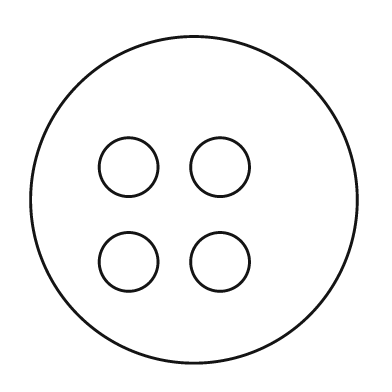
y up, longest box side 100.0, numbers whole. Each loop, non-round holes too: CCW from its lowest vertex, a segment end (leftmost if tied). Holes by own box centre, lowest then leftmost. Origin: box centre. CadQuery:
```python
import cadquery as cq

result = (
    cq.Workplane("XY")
    .moveTo(0.0, 0.0)
    .circle(50.0)
    .moveTo(-20.0, -19.0)
    .circle(9.0)
    .moveTo(8.0, -19.0)
    .circle(9.0)
    .moveTo(-20.0, 10.0)
    .circle(9.0)
    .moveTo(8.0, 10.0)
    .circle(9.0)
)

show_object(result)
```